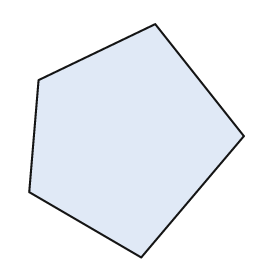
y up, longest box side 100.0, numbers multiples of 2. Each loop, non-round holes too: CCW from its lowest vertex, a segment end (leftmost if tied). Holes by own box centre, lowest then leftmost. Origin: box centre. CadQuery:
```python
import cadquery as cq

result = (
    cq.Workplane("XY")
    .moveTo(2.0, -50.0)
    .lineTo(46.0, 2.0)
    .lineTo(8.0, 50.0)
    .lineTo(-42.0, 26.0)
    .lineTo(-46.0, -22.0)
    .close()
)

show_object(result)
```